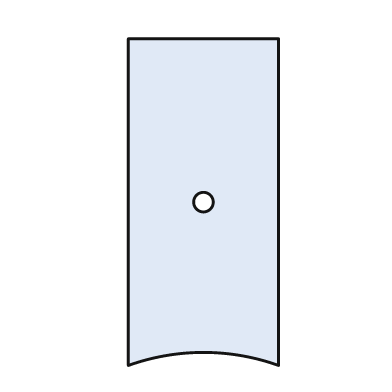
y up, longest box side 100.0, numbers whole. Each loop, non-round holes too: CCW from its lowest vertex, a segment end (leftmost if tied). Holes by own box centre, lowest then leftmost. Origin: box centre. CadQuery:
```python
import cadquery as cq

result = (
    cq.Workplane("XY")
    .moveTo(-23.0, -50.0)
    .threePointArc((0.0, -46.0), (23.0, -50.0))
    .lineTo(23.0, 50.0)
    .lineTo(-23.0, 50.0)
    .close()
    .moveTo(0.0, 0.0)
    .circle(3.0)
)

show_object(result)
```